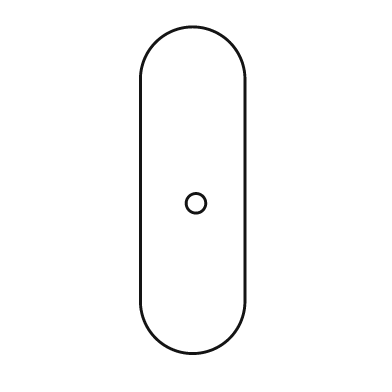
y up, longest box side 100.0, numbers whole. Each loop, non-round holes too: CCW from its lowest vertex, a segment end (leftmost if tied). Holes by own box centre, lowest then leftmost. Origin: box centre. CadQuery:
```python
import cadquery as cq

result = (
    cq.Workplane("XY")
    .moveTo(-16.0, -34.0)
    .threePointArc((0.0, -50.0), (16.0, -34.0))
    .lineTo(16.0, 34.0)
    .threePointArc((0.0, 50.0), (-16.0, 34.0))
    .close()
    .moveTo(1.0, -4.0)
    .circle(3.0)
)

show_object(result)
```